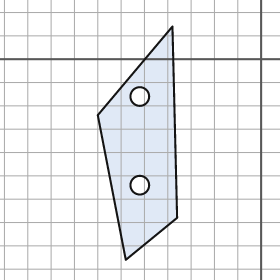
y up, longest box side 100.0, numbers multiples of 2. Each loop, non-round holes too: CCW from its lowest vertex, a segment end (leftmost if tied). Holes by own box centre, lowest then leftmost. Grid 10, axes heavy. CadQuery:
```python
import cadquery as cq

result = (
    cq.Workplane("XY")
    .moveTo(-58.0, -86.0)
    .lineTo(-36.0, -68.0)
    .lineTo(-38.0, 14.0)
    .lineTo(-70.0, -24.0)
    .close()
    .moveTo(-52.0, -54.0)
    .circle(4.0)
    .moveTo(-52.0, -16.0)
    .circle(4.0)
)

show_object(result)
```